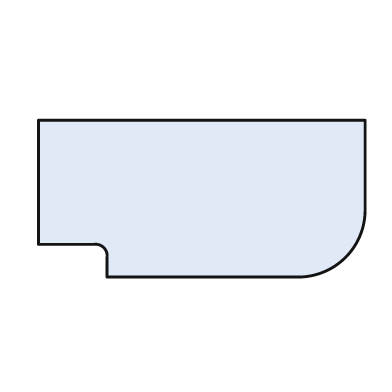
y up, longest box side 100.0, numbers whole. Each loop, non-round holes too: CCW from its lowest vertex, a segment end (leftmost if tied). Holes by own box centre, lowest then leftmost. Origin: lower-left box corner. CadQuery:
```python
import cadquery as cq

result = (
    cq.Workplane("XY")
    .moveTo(21.0, 0.0)
    .lineTo(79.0, 0.0)
    .threePointArc((94.0, 6.0), (100.0, 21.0))
    .lineTo(100.0, 48.0)
    .lineTo(0.0, 48.0)
    .lineTo(0.0, 10.0)
    .lineTo(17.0, 10.0)
    .threePointArc((20.0, 9.0), (21.0, 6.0))
    .close()
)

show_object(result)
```